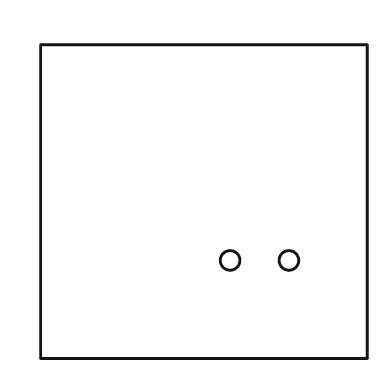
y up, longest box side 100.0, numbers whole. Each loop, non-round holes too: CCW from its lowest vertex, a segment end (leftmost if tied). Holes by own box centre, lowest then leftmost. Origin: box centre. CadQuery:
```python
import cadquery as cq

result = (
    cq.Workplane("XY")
    .moveTo(-50.0, -48.0)
    .lineTo(50.0, -48.0)
    .lineTo(50.0, 48.0)
    .lineTo(-50.0, 48.0)
    .close()
    .moveTo(8.0, -18.0)
    .circle(3.0)
    .moveTo(26.0, -18.0)
    .circle(3.0)
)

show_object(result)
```